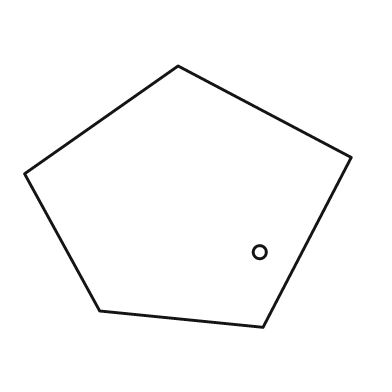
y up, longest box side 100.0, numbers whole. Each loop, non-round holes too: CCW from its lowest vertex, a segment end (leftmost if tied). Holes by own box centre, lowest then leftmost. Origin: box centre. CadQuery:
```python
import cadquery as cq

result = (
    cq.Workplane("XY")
    .moveTo(23.0, -40.0)
    .lineTo(50.0, 12.0)
    .lineTo(-3.0, 40.0)
    .lineTo(-50.0, 7.0)
    .lineTo(-27.0, -35.0)
    .close()
    .moveTo(22.0, -17.0)
    .circle(2.0)
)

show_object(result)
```